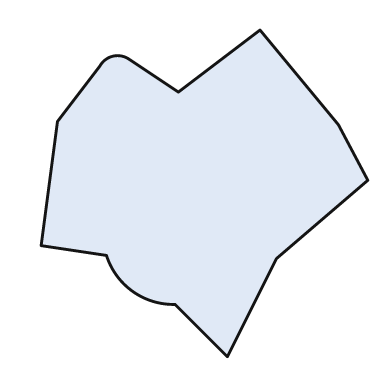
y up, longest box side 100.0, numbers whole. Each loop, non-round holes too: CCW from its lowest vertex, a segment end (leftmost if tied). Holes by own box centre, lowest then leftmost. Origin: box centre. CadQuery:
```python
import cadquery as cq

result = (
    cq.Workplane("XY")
    .moveTo(7.0, -50.0)
    .lineTo(22.0, -20.0)
    .lineTo(50.0, 4.0)
    .lineTo(41.0, 21.0)
    .lineTo(17.0, 50.0)
    .lineTo(-8.0, 31.0)
    .lineTo(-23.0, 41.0)
    .threePointArc((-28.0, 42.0), (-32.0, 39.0))
    .lineTo(-45.0, 22.0)
    .lineTo(-50.0, -16.0)
    .lineTo(-30.0, -19.0)
    .threePointArc((-22.0, -30.0), (-9.0, -34.0))
    .close()
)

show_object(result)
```